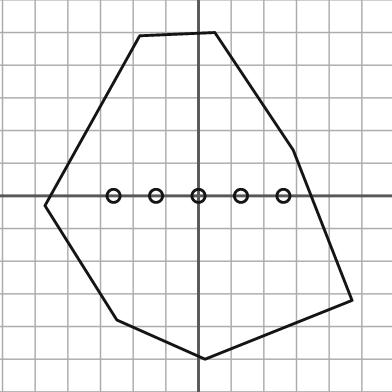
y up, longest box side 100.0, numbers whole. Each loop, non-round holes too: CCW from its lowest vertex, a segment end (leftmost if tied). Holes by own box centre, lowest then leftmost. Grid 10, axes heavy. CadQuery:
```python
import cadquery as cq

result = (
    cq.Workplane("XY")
    .moveTo(2.0, -50.0)
    .lineTo(47.0, -32.0)
    .lineTo(29.0, 14.0)
    .lineTo(5.0, 50.0)
    .lineTo(-18.0, 49.0)
    .lineTo(-47.0, -3.0)
    .lineTo(-25.0, -38.0)
    .close()
    .moveTo(-26.0, 0.0)
    .circle(2.0)
    .moveTo(-13.0, 0.0)
    .circle(2.0)
    .moveTo(0.0, 0.0)
    .circle(2.0)
    .moveTo(13.0, 0.0)
    .circle(2.0)
    .moveTo(26.0, 0.0)
    .circle(2.0)
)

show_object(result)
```